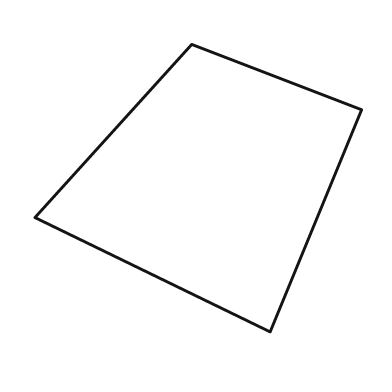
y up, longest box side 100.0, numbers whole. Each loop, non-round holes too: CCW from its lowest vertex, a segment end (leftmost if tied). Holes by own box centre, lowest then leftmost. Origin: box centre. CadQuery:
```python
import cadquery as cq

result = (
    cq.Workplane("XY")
    .moveTo(22.0, -44.0)
    .lineTo(50.0, 24.0)
    .lineTo(-2.0, 44.0)
    .lineTo(-50.0, -9.0)
    .close()
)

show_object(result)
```